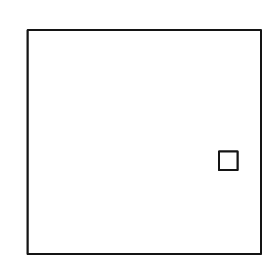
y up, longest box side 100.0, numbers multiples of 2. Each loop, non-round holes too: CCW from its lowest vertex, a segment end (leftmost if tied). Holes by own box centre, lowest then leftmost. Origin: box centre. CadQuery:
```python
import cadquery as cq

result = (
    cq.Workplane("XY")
    .moveTo(-50.0, -48.0)
    .lineTo(50.0, -48.0)
    .lineTo(50.0, 48.0)
    .lineTo(-50.0, 48.0)
    .close()
    .moveTo(32.0, -12.0)
    .lineTo(40.0, -12.0)
    .lineTo(40.0, -4.0)
    .lineTo(32.0, -4.0)
    .close()
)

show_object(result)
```